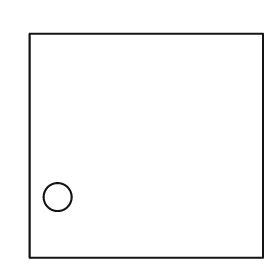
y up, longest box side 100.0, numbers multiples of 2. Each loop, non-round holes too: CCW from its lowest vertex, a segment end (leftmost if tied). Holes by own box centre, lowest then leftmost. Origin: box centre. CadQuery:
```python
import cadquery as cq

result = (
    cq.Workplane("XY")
    .moveTo(-50.0, -48.0)
    .lineTo(50.0, -48.0)
    .lineTo(50.0, 48.0)
    .lineTo(-50.0, 48.0)
    .close()
    .moveTo(-38.0, -22.0)
    .circle(6.0)
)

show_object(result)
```